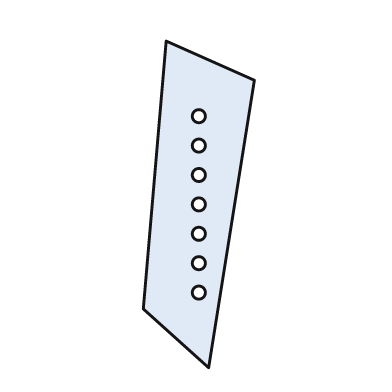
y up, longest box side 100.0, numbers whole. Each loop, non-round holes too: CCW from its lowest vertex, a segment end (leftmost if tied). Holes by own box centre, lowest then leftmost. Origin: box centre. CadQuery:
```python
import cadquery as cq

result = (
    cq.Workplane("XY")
    .moveTo(3.0, -50.0)
    .lineTo(17.0, 38.0)
    .lineTo(-10.0, 50.0)
    .lineTo(-17.0, -32.0)
    .close()
    .moveTo(0.0, -27.0)
    .circle(2.0)
    .moveTo(0.0, -18.0)
    .circle(2.0)
    .moveTo(0.0, -9.0)
    .circle(2.0)
    .moveTo(0.0, 0.0)
    .circle(2.0)
    .moveTo(0.0, 9.0)
    .circle(2.0)
    .moveTo(0.0, 18.0)
    .circle(2.0)
    .moveTo(0.0, 27.0)
    .circle(2.0)
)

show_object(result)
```